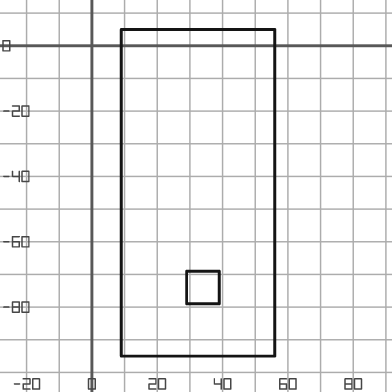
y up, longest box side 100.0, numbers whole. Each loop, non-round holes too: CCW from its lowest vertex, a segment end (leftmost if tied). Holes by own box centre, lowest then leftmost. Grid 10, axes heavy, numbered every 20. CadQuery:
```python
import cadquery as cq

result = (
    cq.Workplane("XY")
    .moveTo(9.0, -95.0)
    .lineTo(56.0, -95.0)
    .lineTo(56.0, 5.0)
    .lineTo(9.0, 5.0)
    .close()
    .moveTo(29.0, -79.0)
    .lineTo(39.0, -79.0)
    .lineTo(39.0, -69.0)
    .lineTo(29.0, -69.0)
    .close()
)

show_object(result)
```